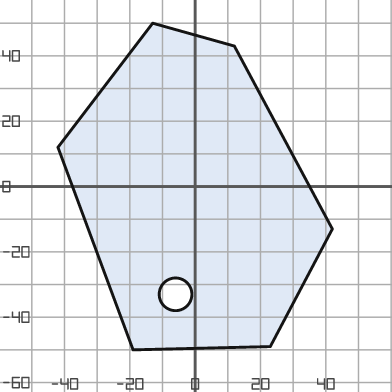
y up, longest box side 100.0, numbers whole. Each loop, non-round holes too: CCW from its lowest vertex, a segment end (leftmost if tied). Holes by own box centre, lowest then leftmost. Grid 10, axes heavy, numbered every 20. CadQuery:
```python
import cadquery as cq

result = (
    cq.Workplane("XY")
    .moveTo(-19.0, -50.0)
    .lineTo(23.0, -49.0)
    .lineTo(42.0, -13.0)
    .lineTo(12.0, 43.0)
    .lineTo(-13.0, 50.0)
    .lineTo(-42.0, 12.0)
    .close()
    .moveTo(-6.0, -33.0)
    .circle(5.0)
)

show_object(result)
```